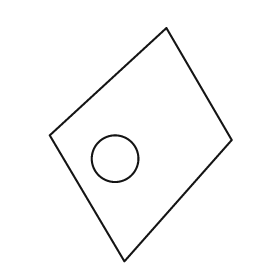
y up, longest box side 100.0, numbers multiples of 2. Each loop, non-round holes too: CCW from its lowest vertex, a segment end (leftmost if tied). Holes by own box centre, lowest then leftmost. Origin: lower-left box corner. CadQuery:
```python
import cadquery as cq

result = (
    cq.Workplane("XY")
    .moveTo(32.0, 0.0)
    .lineTo(78.0, 52.0)
    .lineTo(50.0, 100.0)
    .lineTo(0.0, 54.0)
    .close()
    .moveTo(28.0, 44.0)
    .circle(10.0)
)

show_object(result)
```